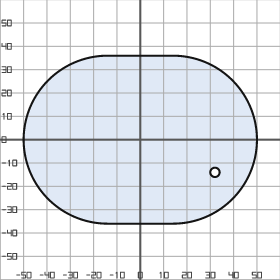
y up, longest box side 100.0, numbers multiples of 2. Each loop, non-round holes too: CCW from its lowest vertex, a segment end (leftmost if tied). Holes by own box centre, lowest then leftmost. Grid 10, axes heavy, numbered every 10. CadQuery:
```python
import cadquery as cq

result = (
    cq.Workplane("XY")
    .moveTo(-14.0, -36.0)
    .lineTo(14.0, -36.0)
    .threePointArc((50.0, 0.0), (14.0, 36.0))
    .lineTo(-14.0, 36.0)
    .threePointArc((-50.0, 0.0), (-14.0, -36.0))
    .close()
    .moveTo(32.0, -14.0)
    .circle(2.0)
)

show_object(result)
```